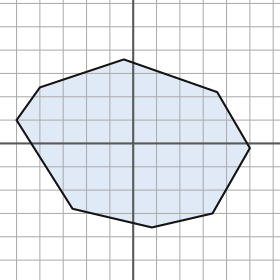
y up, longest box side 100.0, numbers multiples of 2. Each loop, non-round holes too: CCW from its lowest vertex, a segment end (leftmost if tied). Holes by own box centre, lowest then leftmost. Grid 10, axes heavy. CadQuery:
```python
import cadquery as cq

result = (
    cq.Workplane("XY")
    .moveTo(8.0, -36.0)
    .lineTo(34.0, -30.0)
    .lineTo(50.0, -2.0)
    .lineTo(36.0, 22.0)
    .lineTo(-4.0, 36.0)
    .lineTo(-40.0, 24.0)
    .lineTo(-50.0, 10.0)
    .lineTo(-26.0, -28.0)
    .close()
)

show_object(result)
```